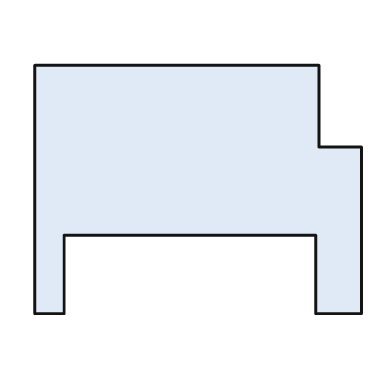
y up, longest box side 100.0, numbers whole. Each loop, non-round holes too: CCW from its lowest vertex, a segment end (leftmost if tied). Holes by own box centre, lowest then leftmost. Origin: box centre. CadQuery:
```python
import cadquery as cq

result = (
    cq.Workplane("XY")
    .moveTo(-50.0, -38.0)
    .lineTo(-41.0, -38.0)
    .lineTo(-41.0, -14.0)
    .lineTo(36.0, -14.0)
    .lineTo(36.0, -38.0)
    .lineTo(50.0, -38.0)
    .lineTo(50.0, 13.0)
    .lineTo(37.0, 13.0)
    .lineTo(37.0, 38.0)
    .lineTo(-50.0, 38.0)
    .close()
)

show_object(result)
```